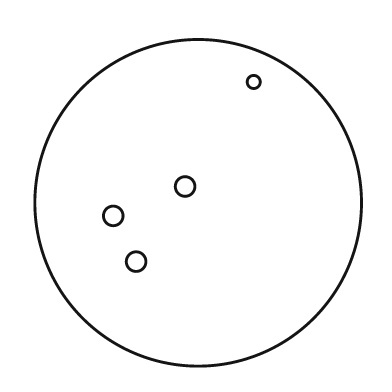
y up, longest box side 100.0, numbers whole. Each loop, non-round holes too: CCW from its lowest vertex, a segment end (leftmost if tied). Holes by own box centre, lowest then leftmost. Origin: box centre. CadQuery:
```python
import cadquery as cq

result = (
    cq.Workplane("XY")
    .moveTo(0.0, 0.0)
    .circle(50.0)
    .moveTo(-19.0, -18.0)
    .circle(3.0)
    .moveTo(-26.0, -4.0)
    .circle(3.0)
    .moveTo(-4.0, 5.0)
    .circle(3.0)
    .moveTo(17.0, 37.0)
    .circle(2.0)
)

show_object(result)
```